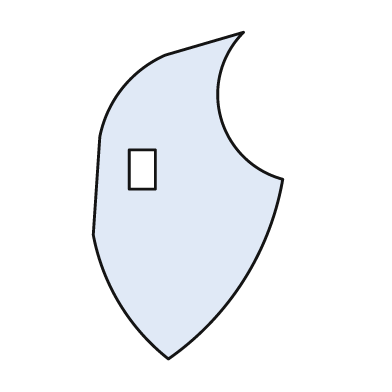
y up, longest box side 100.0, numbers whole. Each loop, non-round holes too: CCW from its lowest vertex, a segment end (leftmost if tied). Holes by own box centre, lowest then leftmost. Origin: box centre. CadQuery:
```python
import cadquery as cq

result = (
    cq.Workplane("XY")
    .moveTo(-6.0, -50.0)
    .threePointArc((17.0, -26.0), (29.0, 5.0))
    .threePointArc((10.0, 24.0), (17.0, 50.0))
    .lineTo(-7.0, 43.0)
    .threePointArc((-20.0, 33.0), (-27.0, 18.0))
    .lineTo(-29.0, -12.0)
    .threePointArc((-21.0, -33.0), (-6.0, -50.0))
    .close()
    .moveTo(-18.0, 2.0)
    .lineTo(-10.0, 2.0)
    .lineTo(-10.0, 14.0)
    .lineTo(-18.0, 14.0)
    .close()
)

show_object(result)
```